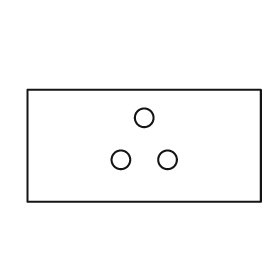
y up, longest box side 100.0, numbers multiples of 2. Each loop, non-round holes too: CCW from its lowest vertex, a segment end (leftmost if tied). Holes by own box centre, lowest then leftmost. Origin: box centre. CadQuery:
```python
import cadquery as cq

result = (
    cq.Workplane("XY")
    .moveTo(-50.0, -24.0)
    .lineTo(50.0, -24.0)
    .lineTo(50.0, 24.0)
    .lineTo(-50.0, 24.0)
    .close()
    .moveTo(-10.0, -6.0)
    .circle(4.0)
    .moveTo(10.0, -6.0)
    .circle(4.0)
    .moveTo(0.0, 12.0)
    .circle(4.0)
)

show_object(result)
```